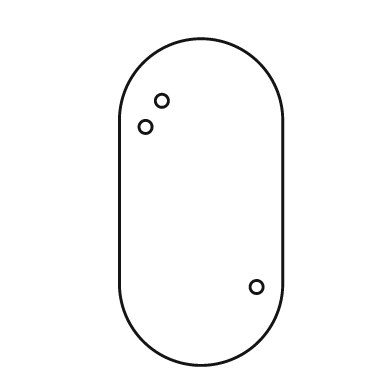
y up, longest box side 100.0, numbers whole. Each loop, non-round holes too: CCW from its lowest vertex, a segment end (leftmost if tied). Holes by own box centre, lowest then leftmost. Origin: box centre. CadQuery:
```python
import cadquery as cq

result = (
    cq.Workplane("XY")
    .moveTo(-25.0, -25.0)
    .threePointArc((0.0, -50.0), (25.0, -25.0))
    .lineTo(25.0, 25.0)
    .threePointArc((0.0, 50.0), (-25.0, 25.0))
    .close()
    .moveTo(17.0, -26.0)
    .circle(2.0)
    .moveTo(-17.0, 23.0)
    .circle(2.0)
    .moveTo(-12.0, 31.0)
    .circle(2.0)
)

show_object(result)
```